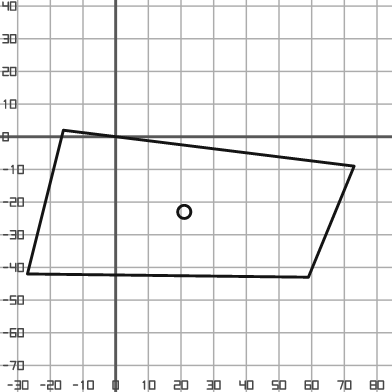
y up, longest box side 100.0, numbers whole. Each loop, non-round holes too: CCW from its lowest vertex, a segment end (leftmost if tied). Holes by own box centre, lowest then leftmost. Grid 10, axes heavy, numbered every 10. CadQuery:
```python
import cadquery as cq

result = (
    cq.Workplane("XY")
    .moveTo(59.0, -43.0)
    .lineTo(73.0, -9.0)
    .lineTo(-16.0, 2.0)
    .lineTo(-27.0, -42.0)
    .close()
    .moveTo(21.0, -23.0)
    .circle(2.0)
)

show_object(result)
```